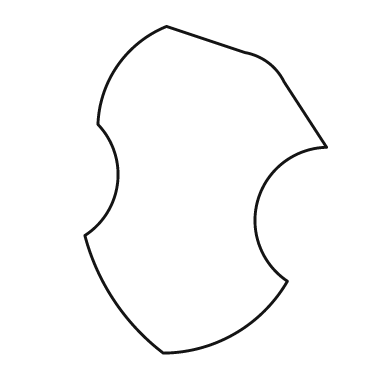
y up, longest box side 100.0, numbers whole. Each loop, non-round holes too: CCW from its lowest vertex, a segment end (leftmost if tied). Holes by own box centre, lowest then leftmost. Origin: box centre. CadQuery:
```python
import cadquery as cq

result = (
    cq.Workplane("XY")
    .moveTo(-13.0, -50.0)
    .threePointArc((9.0, -44.0), (25.0, -28.0))
    .threePointArc((16.0, -3.0), (37.0, 13.0))
    .lineTo(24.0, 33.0)
    .threePointArc((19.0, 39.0), (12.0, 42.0))
    .lineTo(-12.0, 50.0)
    .threePointArc((-27.0, 38.0), (-33.0, 20.0))
    .threePointArc((-27.0, 2.0), (-37.0, -14.0))
    .threePointArc((-28.0, -34.0), (-13.0, -50.0))
    .close()
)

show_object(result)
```